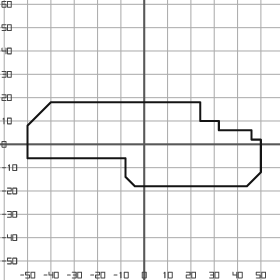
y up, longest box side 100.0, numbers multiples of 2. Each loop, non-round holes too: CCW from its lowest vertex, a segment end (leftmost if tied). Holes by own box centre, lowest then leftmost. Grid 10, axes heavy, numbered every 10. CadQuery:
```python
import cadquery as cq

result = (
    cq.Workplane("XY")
    .moveTo(-4.0, -18.0)
    .lineTo(44.0, -18.0)
    .lineTo(50.0, -12.0)
    .lineTo(50.0, 2.0)
    .lineTo(46.0, 2.0)
    .lineTo(46.0, 6.0)
    .lineTo(32.0, 6.0)
    .lineTo(32.0, 10.0)
    .lineTo(24.0, 10.0)
    .lineTo(24.0, 18.0)
    .lineTo(-40.0, 18.0)
    .lineTo(-50.0, 8.0)
    .lineTo(-50.0, -6.0)
    .lineTo(-8.0, -6.0)
    .lineTo(-8.0, -14.0)
    .close()
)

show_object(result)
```